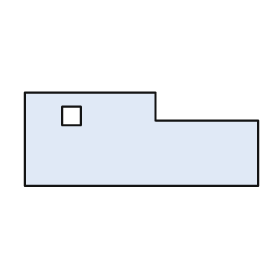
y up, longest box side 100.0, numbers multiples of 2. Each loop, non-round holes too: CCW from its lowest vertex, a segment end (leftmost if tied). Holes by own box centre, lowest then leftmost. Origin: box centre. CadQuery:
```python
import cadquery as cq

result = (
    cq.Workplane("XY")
    .moveTo(-50.0, -20.0)
    .lineTo(50.0, -20.0)
    .lineTo(50.0, 8.0)
    .lineTo(6.0, 8.0)
    .lineTo(6.0, 20.0)
    .lineTo(-50.0, 20.0)
    .close()
    .moveTo(-34.0, 6.0)
    .lineTo(-26.0, 6.0)
    .lineTo(-26.0, 14.0)
    .lineTo(-34.0, 14.0)
    .close()
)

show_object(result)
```